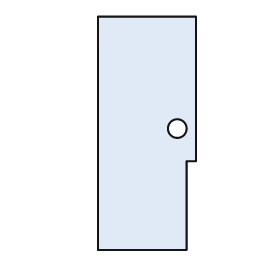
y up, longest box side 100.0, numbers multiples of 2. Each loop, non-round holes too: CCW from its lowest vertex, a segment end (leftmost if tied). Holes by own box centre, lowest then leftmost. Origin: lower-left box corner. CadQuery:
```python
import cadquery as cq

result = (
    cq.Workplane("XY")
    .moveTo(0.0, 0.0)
    .lineTo(38.0, 0.0)
    .lineTo(38.0, 38.0)
    .lineTo(42.0, 38.0)
    .lineTo(42.0, 100.0)
    .lineTo(0.0, 100.0)
    .close()
    .moveTo(34.0, 52.0)
    .circle(4.0)
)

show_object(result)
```